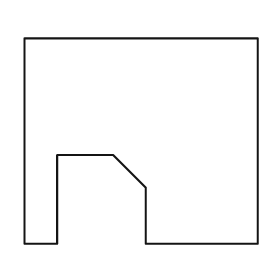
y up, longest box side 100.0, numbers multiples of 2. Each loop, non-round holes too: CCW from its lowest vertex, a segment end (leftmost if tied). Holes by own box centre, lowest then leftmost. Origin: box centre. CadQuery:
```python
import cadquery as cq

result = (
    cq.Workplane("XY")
    .moveTo(-50.0, -44.0)
    .lineTo(-36.0, -44.0)
    .lineTo(-36.0, -6.0)
    .lineTo(-12.0, -6.0)
    .lineTo(2.0, -20.0)
    .lineTo(2.0, -44.0)
    .lineTo(50.0, -44.0)
    .lineTo(50.0, 44.0)
    .lineTo(-50.0, 44.0)
    .close()
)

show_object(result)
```